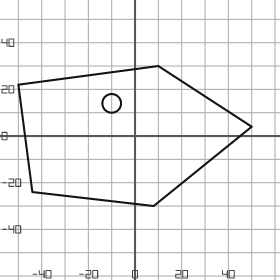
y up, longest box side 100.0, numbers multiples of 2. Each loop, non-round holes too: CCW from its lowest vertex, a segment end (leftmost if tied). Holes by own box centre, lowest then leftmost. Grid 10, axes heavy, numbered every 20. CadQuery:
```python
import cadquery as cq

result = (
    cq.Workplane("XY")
    .moveTo(8.0, -30.0)
    .lineTo(50.0, 4.0)
    .lineTo(10.0, 30.0)
    .lineTo(-50.0, 22.0)
    .lineTo(-44.0, -24.0)
    .close()
    .moveTo(-10.0, 14.0)
    .circle(4.0)
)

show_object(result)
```